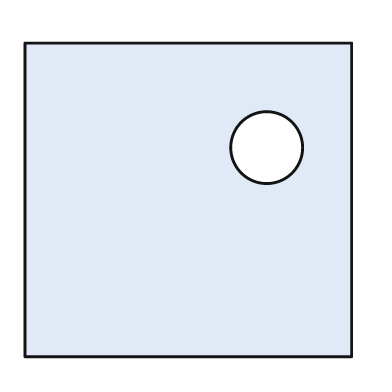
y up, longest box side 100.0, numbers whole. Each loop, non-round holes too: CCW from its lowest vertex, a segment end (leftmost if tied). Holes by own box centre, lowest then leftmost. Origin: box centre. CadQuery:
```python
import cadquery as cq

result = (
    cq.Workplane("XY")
    .moveTo(-50.0, -48.0)
    .lineTo(50.0, -48.0)
    .lineTo(50.0, 48.0)
    .lineTo(-50.0, 48.0)
    .close()
    .moveTo(24.0, 16.0)
    .circle(11.0)
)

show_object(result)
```